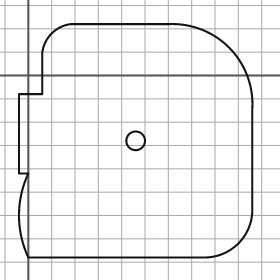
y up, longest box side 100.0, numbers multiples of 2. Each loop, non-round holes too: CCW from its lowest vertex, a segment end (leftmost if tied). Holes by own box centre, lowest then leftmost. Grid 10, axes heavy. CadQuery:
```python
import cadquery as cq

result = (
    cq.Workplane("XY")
    .moveTo(0.0, -78.0)
    .lineTo(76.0, -78.0)
    .threePointArc((90.0, -72.0), (96.0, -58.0))
    .lineTo(96.0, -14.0)
    .threePointArc((86.0, 12.0), (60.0, 22.0))
    .lineTo(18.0, 22.0)
    .threePointArc((10.0, 18.0), (6.0, 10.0))
    .lineTo(6.0, -8.0)
    .lineTo(-4.0, -8.0)
    .lineTo(-4.0, -42.0)
    .lineTo(0.0, -42.0)
    .threePointArc((-4.0, -60.0), (0.0, -78.0))
    .close()
    .moveTo(46.0, -28.0)
    .circle(4.0)
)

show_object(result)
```